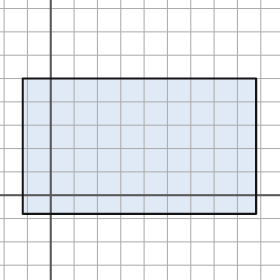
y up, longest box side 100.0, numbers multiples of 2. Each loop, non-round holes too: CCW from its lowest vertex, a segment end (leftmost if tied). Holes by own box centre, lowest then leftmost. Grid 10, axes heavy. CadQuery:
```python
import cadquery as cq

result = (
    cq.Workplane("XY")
    .moveTo(-12.0, -8.0)
    .lineTo(88.0, -8.0)
    .lineTo(88.0, 50.0)
    .lineTo(-12.0, 50.0)
    .close()
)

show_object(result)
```